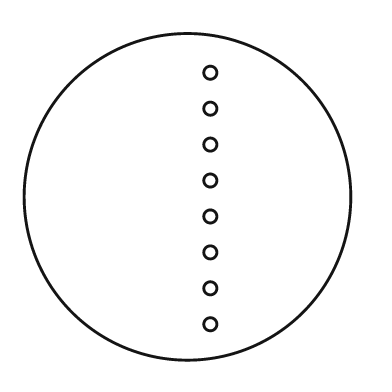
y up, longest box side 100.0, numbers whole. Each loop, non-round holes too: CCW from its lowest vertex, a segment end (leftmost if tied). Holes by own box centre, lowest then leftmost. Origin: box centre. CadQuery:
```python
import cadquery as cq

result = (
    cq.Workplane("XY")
    .moveTo(0.0, 0.0)
    .circle(50.0)
    .moveTo(7.0, -39.0)
    .circle(2.0)
    .moveTo(7.0, -28.0)
    .circle(2.0)
    .moveTo(7.0, -17.0)
    .circle(2.0)
    .moveTo(7.0, -6.0)
    .circle(2.0)
    .moveTo(7.0, 5.0)
    .circle(2.0)
    .moveTo(7.0, 16.0)
    .circle(2.0)
    .moveTo(7.0, 27.0)
    .circle(2.0)
    .moveTo(7.0, 38.0)
    .circle(2.0)
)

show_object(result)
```